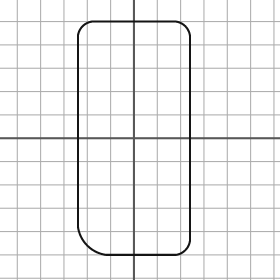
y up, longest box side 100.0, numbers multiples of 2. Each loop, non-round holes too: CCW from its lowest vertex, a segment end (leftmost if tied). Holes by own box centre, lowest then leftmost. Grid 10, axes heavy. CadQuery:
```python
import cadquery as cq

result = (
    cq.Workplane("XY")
    .moveTo(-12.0, -50.0)
    .lineTo(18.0, -50.0)
    .threePointArc((22.0, -48.0), (24.0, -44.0))
    .lineTo(24.0, 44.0)
    .threePointArc((22.0, 48.0), (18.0, 50.0))
    .lineTo(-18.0, 50.0)
    .threePointArc((-22.0, 48.0), (-24.0, 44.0))
    .lineTo(-24.0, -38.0)
    .threePointArc((-20.0, -46.0), (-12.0, -50.0))
    .close()
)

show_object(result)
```